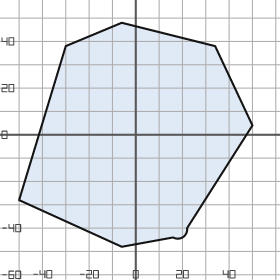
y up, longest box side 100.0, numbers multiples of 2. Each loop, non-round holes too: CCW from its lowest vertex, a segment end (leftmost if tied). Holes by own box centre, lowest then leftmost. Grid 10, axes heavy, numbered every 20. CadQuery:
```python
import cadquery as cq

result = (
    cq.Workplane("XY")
    .moveTo(-6.0, -48.0)
    .lineTo(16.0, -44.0)
    .threePointArc((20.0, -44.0), (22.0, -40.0))
    .lineTo(50.0, 4.0)
    .lineTo(34.0, 38.0)
    .lineTo(-6.0, 48.0)
    .lineTo(-30.0, 38.0)
    .lineTo(-50.0, -28.0)
    .close()
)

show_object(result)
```